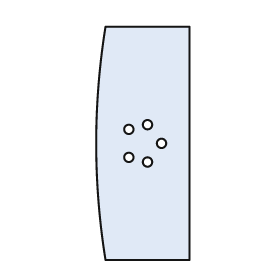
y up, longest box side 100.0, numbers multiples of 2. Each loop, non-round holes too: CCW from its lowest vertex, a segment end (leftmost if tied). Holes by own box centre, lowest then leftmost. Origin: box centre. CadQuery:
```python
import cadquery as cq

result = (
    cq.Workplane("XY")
    .moveTo(-16.0, -50.0)
    .lineTo(20.0, -50.0)
    .lineTo(20.0, 50.0)
    .lineTo(-16.0, 50.0)
    .threePointArc((-20.0, 0.0), (-16.0, -50.0))
    .close()
    .moveTo(2.0, -8.0)
    .circle(2.0)
    .moveTo(-6.0, -6.0)
    .circle(2.0)
    .moveTo(8.0, 0.0)
    .circle(2.0)
    .moveTo(-6.0, 6.0)
    .circle(2.0)
    .moveTo(2.0, 8.0)
    .circle(2.0)
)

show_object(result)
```